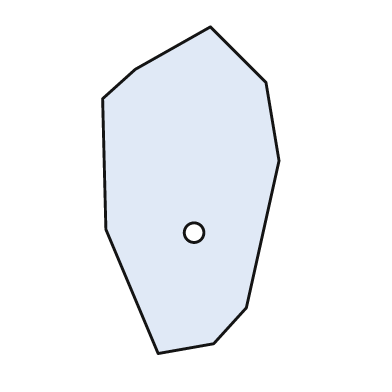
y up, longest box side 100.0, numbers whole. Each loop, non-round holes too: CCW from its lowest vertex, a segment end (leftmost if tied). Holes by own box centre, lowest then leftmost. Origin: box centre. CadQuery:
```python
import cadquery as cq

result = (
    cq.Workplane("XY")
    .moveTo(-10.0, -50.0)
    .lineTo(7.0, -47.0)
    .lineTo(17.0, -36.0)
    .lineTo(27.0, 9.0)
    .lineTo(23.0, 33.0)
    .lineTo(6.0, 50.0)
    .lineTo(-17.0, 37.0)
    .lineTo(-27.0, 28.0)
    .lineTo(-26.0, -12.0)
    .close()
    .moveTo(1.0, -13.0)
    .circle(3.0)
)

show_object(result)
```